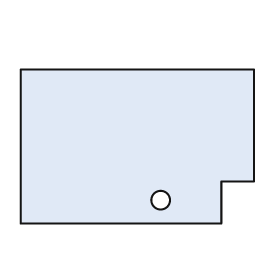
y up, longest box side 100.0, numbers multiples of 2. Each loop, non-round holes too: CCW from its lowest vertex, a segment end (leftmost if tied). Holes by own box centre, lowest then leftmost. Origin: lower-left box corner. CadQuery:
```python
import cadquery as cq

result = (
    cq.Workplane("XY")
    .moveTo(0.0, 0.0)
    .lineTo(86.0, 0.0)
    .lineTo(86.0, 18.0)
    .lineTo(100.0, 18.0)
    .lineTo(100.0, 66.0)
    .lineTo(0.0, 66.0)
    .close()
    .moveTo(60.0, 10.0)
    .circle(4.0)
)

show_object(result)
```